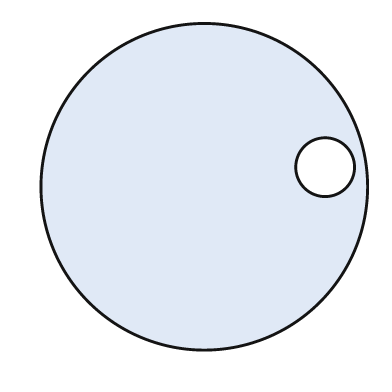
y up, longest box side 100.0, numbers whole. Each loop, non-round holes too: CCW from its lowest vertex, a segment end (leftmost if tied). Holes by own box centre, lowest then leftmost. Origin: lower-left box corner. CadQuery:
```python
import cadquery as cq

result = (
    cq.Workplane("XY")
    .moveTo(50.0, 50.0)
    .circle(50.0)
    .moveTo(87.0, 56.0)
    .circle(9.0)
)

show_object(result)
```